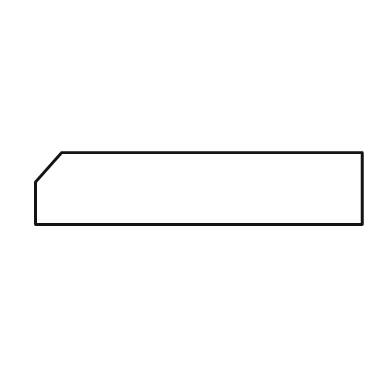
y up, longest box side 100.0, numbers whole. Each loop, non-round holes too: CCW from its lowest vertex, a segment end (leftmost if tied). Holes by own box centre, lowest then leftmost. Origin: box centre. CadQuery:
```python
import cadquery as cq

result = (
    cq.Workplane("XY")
    .moveTo(-50.0, -11.0)
    .lineTo(50.0, -11.0)
    .lineTo(50.0, 11.0)
    .lineTo(-42.0, 11.0)
    .lineTo(-50.0, 2.0)
    .close()
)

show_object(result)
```